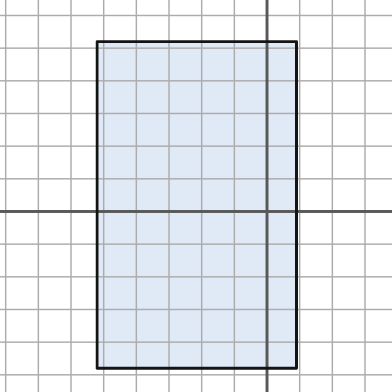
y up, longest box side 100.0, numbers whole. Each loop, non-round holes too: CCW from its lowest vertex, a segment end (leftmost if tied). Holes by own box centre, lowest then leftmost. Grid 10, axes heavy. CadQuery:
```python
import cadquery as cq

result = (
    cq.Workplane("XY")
    .moveTo(-52.0, -48.0)
    .lineTo(9.0, -48.0)
    .lineTo(9.0, 52.0)
    .lineTo(-52.0, 52.0)
    .close()
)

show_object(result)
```